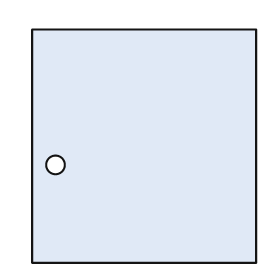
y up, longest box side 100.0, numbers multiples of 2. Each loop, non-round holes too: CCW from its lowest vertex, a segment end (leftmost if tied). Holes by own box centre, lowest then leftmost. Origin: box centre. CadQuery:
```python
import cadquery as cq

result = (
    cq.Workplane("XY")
    .moveTo(-48.0, -50.0)
    .lineTo(48.0, -50.0)
    .lineTo(48.0, 50.0)
    .lineTo(-48.0, 50.0)
    .close()
    .moveTo(-38.0, -8.0)
    .circle(4.0)
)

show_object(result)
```